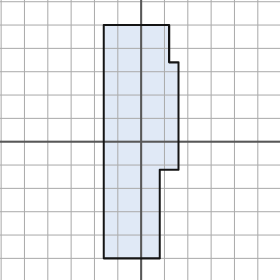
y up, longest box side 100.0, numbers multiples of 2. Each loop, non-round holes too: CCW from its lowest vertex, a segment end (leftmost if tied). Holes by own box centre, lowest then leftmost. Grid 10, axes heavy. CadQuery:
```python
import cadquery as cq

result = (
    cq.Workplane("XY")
    .moveTo(-16.0, -50.0)
    .lineTo(8.0, -50.0)
    .lineTo(8.0, -12.0)
    .lineTo(16.0, -12.0)
    .lineTo(16.0, 34.0)
    .lineTo(12.0, 34.0)
    .lineTo(12.0, 50.0)
    .lineTo(-16.0, 50.0)
    .close()
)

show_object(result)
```